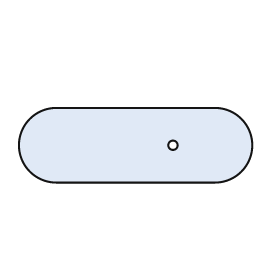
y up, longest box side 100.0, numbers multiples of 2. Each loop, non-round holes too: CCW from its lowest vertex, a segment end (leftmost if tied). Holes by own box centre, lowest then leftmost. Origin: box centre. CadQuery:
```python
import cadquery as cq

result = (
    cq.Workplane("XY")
    .moveTo(-34.0, -16.0)
    .lineTo(34.0, -16.0)
    .threePointArc((50.0, 0.0), (34.0, 16.0))
    .lineTo(-34.0, 16.0)
    .threePointArc((-50.0, 0.0), (-34.0, -16.0))
    .close()
    .moveTo(16.0, 0.0)
    .circle(2.0)
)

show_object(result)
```